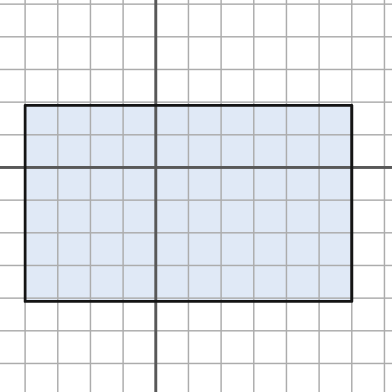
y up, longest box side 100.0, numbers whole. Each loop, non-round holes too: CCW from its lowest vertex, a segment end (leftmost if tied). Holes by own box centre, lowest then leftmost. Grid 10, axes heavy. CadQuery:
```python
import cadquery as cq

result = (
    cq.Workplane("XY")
    .moveTo(-40.0, -41.0)
    .lineTo(60.0, -41.0)
    .lineTo(60.0, 19.0)
    .lineTo(-40.0, 19.0)
    .close()
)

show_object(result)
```